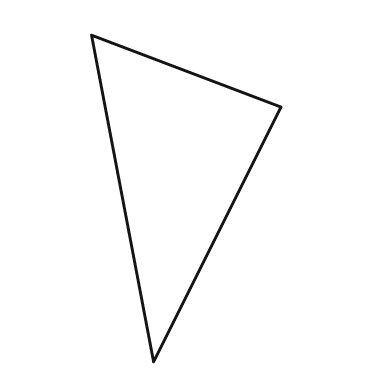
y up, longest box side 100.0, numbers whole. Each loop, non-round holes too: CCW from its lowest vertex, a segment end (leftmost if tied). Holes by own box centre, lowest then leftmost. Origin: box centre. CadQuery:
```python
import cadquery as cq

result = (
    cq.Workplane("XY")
    .moveTo(-10.0, -50.0)
    .lineTo(29.0, 28.0)
    .lineTo(-29.0, 50.0)
    .close()
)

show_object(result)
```